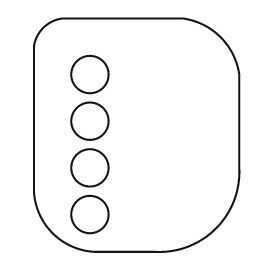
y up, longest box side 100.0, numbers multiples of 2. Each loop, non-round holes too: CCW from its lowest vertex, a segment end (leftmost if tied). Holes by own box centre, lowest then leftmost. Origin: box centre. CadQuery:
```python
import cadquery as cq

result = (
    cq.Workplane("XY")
    .moveTo(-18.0, -50.0)
    .lineTo(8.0, -50.0)
    .threePointArc((34.0, -40.0), (44.0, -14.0))
    .lineTo(44.0, 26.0)
    .threePointArc((36.0, 42.0), (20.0, 50.0))
    .lineTo(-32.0, 50.0)
    .threePointArc((-40.0, 46.0), (-44.0, 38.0))
    .lineTo(-44.0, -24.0)
    .threePointArc((-36.0, -42.0), (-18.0, -50.0))
    .close()
    .moveTo(-20.0, -34.0)
    .circle(8.0)
    .moveTo(-20.0, -14.0)
    .circle(8.0)
    .moveTo(-20.0, 6.0)
    .circle(8.0)
    .moveTo(-20.0, 26.0)
    .circle(8.0)
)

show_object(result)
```